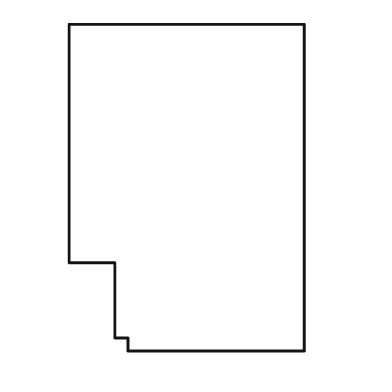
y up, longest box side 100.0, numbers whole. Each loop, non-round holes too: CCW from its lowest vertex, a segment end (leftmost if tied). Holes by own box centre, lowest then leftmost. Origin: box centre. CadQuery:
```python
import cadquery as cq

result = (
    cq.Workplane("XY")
    .moveTo(-18.0, -50.0)
    .lineTo(36.0, -50.0)
    .lineTo(36.0, 50.0)
    .lineTo(-36.0, 50.0)
    .lineTo(-36.0, -23.0)
    .lineTo(-22.0, -23.0)
    .lineTo(-22.0, -46.0)
    .lineTo(-18.0, -46.0)
    .close()
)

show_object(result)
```